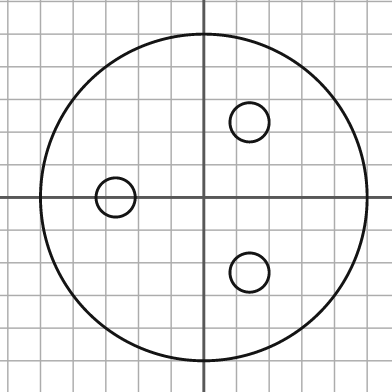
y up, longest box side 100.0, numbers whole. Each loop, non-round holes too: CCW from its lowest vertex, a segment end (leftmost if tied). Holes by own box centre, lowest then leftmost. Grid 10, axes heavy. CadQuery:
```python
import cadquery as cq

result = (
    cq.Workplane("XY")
    .moveTo(0.0, 0.0)
    .circle(50.0)
    .moveTo(14.0, -23.0)
    .circle(6.0)
    .moveTo(-27.0, 0.0)
    .circle(6.0)
    .moveTo(14.0, 23.0)
    .circle(6.0)
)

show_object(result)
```